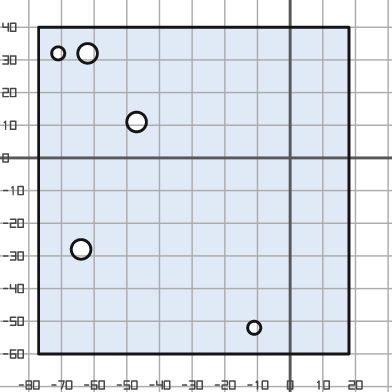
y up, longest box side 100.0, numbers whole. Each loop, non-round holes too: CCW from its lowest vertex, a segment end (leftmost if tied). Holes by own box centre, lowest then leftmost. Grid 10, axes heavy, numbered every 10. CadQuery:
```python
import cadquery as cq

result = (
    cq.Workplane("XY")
    .moveTo(-77.0, -60.0)
    .lineTo(18.0, -60.0)
    .lineTo(18.0, 40.0)
    .lineTo(-77.0, 40.0)
    .close()
    .moveTo(-11.0, -52.0)
    .circle(2.0)
    .moveTo(-64.0, -28.0)
    .circle(3.0)
    .moveTo(-47.0, 11.0)
    .circle(3.0)
    .moveTo(-71.0, 32.0)
    .circle(2.0)
    .moveTo(-62.0, 32.0)
    .circle(3.0)
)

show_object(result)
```